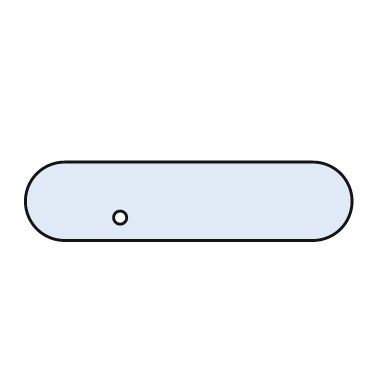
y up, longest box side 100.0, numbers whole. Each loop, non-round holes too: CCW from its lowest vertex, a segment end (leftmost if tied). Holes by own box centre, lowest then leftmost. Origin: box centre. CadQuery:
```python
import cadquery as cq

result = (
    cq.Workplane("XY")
    .moveTo(-38.0, -12.0)
    .lineTo(38.0, -12.0)
    .threePointArc((50.0, 0.0), (38.0, 12.0))
    .lineTo(-38.0, 12.0)
    .threePointArc((-50.0, 0.0), (-38.0, -12.0))
    .close()
    .moveTo(-21.0, -5.0)
    .circle(2.0)
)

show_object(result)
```